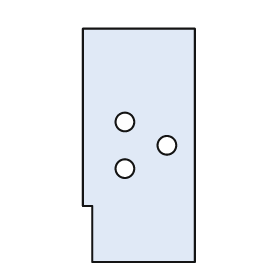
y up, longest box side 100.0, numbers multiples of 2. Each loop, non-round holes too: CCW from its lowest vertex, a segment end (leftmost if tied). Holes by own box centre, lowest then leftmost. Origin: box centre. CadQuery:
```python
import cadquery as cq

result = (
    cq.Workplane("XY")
    .moveTo(-20.0, -50.0)
    .lineTo(24.0, -50.0)
    .lineTo(24.0, 50.0)
    .lineTo(-24.0, 50.0)
    .lineTo(-24.0, -26.0)
    .lineTo(-20.0, -26.0)
    .close()
    .moveTo(-6.0, -10.0)
    .circle(4.0)
    .moveTo(12.0, 0.0)
    .circle(4.0)
    .moveTo(-6.0, 10.0)
    .circle(4.0)
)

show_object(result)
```